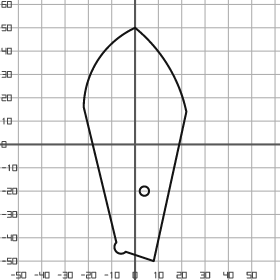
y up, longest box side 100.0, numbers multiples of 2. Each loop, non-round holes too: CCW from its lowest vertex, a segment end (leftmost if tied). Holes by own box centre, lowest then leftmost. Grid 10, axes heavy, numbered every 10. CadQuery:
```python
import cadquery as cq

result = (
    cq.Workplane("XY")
    .moveTo(8.0, -50.0)
    .lineTo(22.0, 14.0)
    .threePointArc((14.0, 34.0), (0.0, 50.0))
    .threePointArc((-16.0, 36.0), (-22.0, 16.0))
    .lineTo(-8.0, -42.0)
    .threePointArc((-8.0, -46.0), (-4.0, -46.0))
    .close()
    .moveTo(4.0, -20.0)
    .circle(2.0)
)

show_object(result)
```